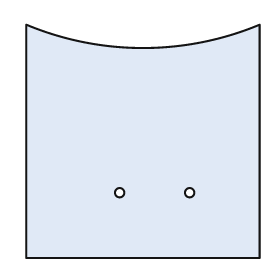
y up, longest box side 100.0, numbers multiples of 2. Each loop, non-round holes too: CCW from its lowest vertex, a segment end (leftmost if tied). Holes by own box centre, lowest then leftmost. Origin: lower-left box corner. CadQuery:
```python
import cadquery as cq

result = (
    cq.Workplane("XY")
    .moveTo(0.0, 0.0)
    .lineTo(100.0, 0.0)
    .lineTo(100.0, 100.0)
    .threePointArc((50.0, 90.0), (0.0, 100.0))
    .close()
    .moveTo(40.0, 28.0)
    .circle(2.0)
    .moveTo(70.0, 28.0)
    .circle(2.0)
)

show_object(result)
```